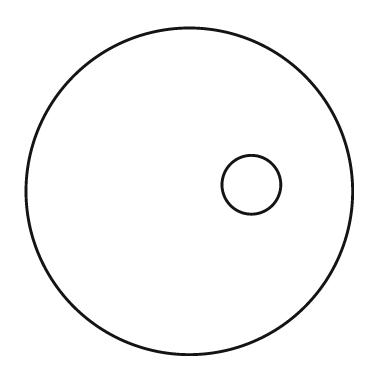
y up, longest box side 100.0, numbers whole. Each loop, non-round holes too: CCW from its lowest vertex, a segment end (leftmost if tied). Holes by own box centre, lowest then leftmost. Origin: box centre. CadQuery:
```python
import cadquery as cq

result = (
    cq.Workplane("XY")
    .moveTo(0.0, 0.0)
    .circle(50.0)
    .moveTo(19.0, 2.0)
    .circle(9.0)
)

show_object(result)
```